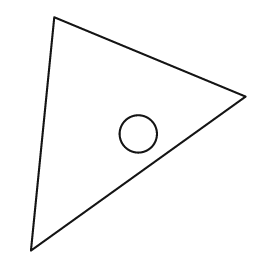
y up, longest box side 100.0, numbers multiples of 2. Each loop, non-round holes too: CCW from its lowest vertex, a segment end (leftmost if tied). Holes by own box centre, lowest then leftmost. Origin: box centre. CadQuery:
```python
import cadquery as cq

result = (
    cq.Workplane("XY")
    .moveTo(-46.0, -50.0)
    .lineTo(46.0, 16.0)
    .lineTo(-36.0, 50.0)
    .close()
    .moveTo(0.0, 0.0)
    .circle(8.0)
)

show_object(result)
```